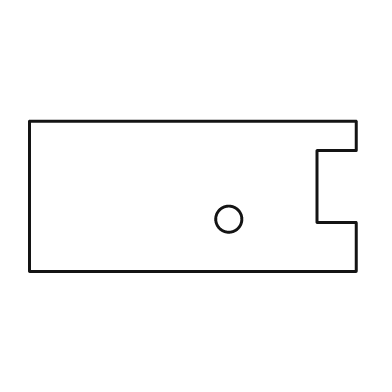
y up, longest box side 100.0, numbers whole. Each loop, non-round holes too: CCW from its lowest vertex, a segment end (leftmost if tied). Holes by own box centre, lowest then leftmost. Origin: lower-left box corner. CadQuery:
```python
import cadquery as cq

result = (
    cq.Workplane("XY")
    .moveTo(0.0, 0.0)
    .lineTo(100.0, 0.0)
    .lineTo(100.0, 15.0)
    .lineTo(88.0, 15.0)
    .lineTo(88.0, 37.0)
    .lineTo(100.0, 37.0)
    .lineTo(100.0, 46.0)
    .lineTo(0.0, 46.0)
    .close()
    .moveTo(61.0, 16.0)
    .circle(4.0)
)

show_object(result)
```